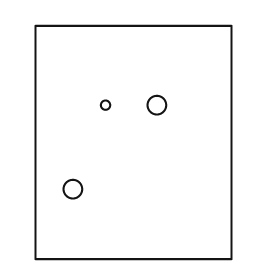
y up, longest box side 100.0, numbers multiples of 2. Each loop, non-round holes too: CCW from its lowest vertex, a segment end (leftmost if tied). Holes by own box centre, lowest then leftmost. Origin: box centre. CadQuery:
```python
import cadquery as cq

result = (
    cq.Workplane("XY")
    .moveTo(-42.0, -50.0)
    .lineTo(42.0, -50.0)
    .lineTo(42.0, 50.0)
    .lineTo(-42.0, 50.0)
    .close()
    .moveTo(-26.0, -20.0)
    .circle(4.0)
    .moveTo(-12.0, 16.0)
    .circle(2.0)
    .moveTo(10.0, 16.0)
    .circle(4.0)
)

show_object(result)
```